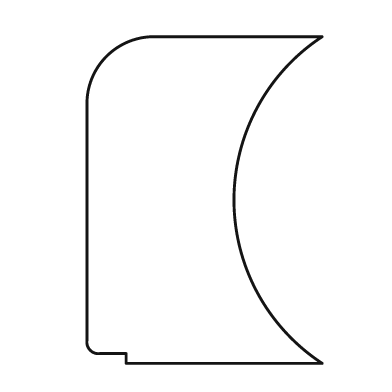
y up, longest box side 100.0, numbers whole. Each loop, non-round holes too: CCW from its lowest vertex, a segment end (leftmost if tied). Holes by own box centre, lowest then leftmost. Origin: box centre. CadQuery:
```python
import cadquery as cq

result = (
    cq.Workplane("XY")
    .moveTo(-24.0, -50.0)
    .lineTo(36.0, -50.0)
    .threePointArc((9.0, 0.0), (36.0, 50.0))
    .lineTo(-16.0, 50.0)
    .threePointArc((-30.0, 44.0), (-36.0, 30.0))
    .lineTo(-36.0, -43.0)
    .threePointArc((-35.0, -46.0), (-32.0, -47.0))
    .lineTo(-24.0, -47.0)
    .close()
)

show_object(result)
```